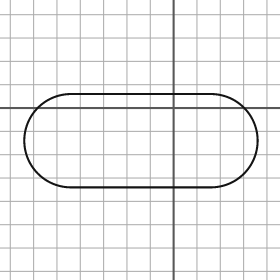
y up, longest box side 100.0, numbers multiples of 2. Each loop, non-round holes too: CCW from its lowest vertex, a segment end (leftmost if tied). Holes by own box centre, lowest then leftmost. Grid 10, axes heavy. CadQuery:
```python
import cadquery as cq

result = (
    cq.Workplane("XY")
    .moveTo(-44.0, -34.0)
    .lineTo(16.0, -34.0)
    .threePointArc((36.0, -14.0), (16.0, 6.0))
    .lineTo(-44.0, 6.0)
    .threePointArc((-64.0, -14.0), (-44.0, -34.0))
    .close()
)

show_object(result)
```